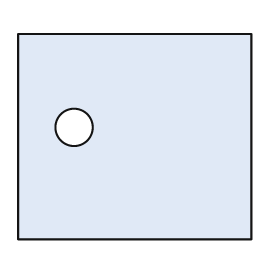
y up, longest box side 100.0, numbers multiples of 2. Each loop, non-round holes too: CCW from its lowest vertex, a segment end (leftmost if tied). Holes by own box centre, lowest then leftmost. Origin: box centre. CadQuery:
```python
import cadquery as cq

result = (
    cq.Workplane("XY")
    .moveTo(-50.0, -44.0)
    .lineTo(50.0, -44.0)
    .lineTo(50.0, 44.0)
    .lineTo(-50.0, 44.0)
    .close()
    .moveTo(-26.0, 4.0)
    .circle(8.0)
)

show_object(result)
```